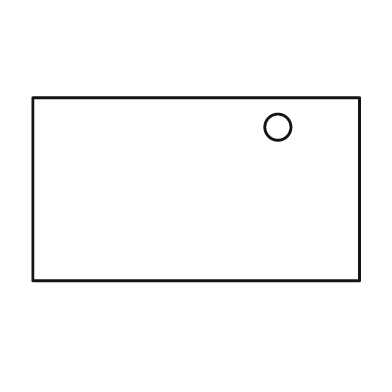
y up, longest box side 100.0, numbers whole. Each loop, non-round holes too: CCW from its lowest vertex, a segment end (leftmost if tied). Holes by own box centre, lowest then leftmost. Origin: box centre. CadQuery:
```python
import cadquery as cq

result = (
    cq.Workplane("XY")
    .moveTo(-50.0, -28.0)
    .lineTo(50.0, -28.0)
    .lineTo(50.0, 28.0)
    .lineTo(-50.0, 28.0)
    .close()
    .moveTo(25.0, 19.0)
    .circle(4.0)
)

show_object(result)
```